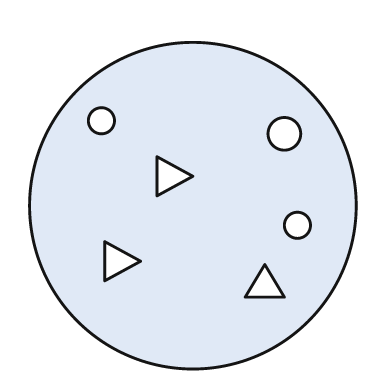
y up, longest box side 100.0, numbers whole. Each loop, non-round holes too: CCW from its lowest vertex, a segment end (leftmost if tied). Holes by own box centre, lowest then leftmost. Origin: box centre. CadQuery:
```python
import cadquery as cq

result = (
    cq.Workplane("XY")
    .moveTo(0.0, 0.0)
    .circle(50.0)
    .moveTo(16.0, -28.0)
    .lineTo(28.0, -28.0)
    .lineTo(22.0, -18.0)
    .close()
    .moveTo(-27.0, -23.0)
    .lineTo(-16.0, -17.0)
    .lineTo(-27.0, -11.0)
    .close()
    .moveTo(32.0, -6.0)
    .circle(4.0)
    .moveTo(-11.0, 3.0)
    .lineTo(0.0, 9.0)
    .lineTo(-11.0, 15.0)
    .close()
    .moveTo(28.0, 22.0)
    .circle(5.0)
    .moveTo(-28.0, 26.0)
    .circle(4.0)
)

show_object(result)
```